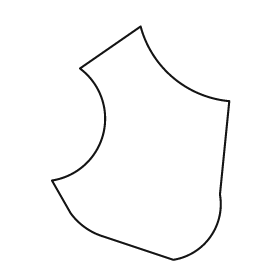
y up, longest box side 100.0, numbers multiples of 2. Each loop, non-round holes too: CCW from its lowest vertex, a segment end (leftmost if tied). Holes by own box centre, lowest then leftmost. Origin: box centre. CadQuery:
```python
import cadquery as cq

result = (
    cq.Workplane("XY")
    .moveTo(14.0, -50.0)
    .threePointArc((30.0, -40.0), (34.0, -22.0))
    .lineTo(38.0, 18.0)
    .threePointArc((14.0, 28.0), (0.0, 50.0))
    .lineTo(-26.0, 32.0)
    .threePointArc((-16.0, 4.0), (-38.0, -16.0))
    .lineTo(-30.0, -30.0)
    .threePointArc((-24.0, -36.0), (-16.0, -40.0))
    .close()
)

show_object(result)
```